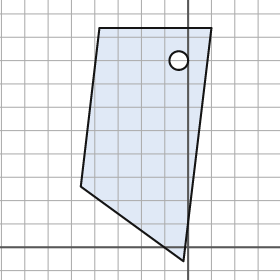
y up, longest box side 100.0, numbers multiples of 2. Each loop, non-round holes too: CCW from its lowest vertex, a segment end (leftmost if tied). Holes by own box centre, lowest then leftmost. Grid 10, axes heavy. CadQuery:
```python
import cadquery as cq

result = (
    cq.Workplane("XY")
    .moveTo(-2.0, -6.0)
    .lineTo(10.0, 94.0)
    .lineTo(-38.0, 94.0)
    .lineTo(-46.0, 26.0)
    .close()
    .moveTo(-4.0, 80.0)
    .circle(4.0)
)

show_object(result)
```